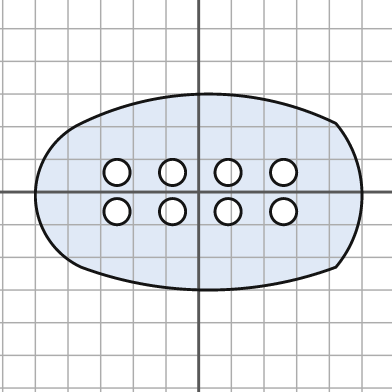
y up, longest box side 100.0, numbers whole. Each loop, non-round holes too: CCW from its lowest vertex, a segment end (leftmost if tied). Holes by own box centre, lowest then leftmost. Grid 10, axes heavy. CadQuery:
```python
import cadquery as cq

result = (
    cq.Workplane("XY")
    .moveTo(-36.0, -23.0)
    .threePointArc((3.0, -30.0), (42.0, -23.0))
    .threePointArc((50.0, -1.0), (42.0, 21.0))
    .threePointArc((3.0, 30.0), (-36.0, 21.0))
    .threePointArc((-50.0, -1.0), (-36.0, -23.0))
    .close()
    .moveTo(-25.0, -6.0)
    .circle(4.0)
    .moveTo(-8.0, -6.0)
    .circle(4.0)
    .moveTo(9.0, -6.0)
    .circle(4.0)
    .moveTo(26.0, -6.0)
    .circle(4.0)
    .moveTo(-25.0, 6.0)
    .circle(4.0)
    .moveTo(-8.0, 6.0)
    .circle(4.0)
    .moveTo(9.0, 6.0)
    .circle(4.0)
    .moveTo(26.0, 6.0)
    .circle(4.0)
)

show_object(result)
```